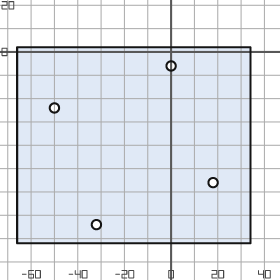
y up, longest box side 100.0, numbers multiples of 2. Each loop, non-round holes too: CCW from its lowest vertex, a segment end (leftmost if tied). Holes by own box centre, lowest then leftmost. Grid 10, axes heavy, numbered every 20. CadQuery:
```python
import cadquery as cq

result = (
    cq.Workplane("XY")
    .moveTo(-66.0, -82.0)
    .lineTo(34.0, -82.0)
    .lineTo(34.0, 2.0)
    .lineTo(-66.0, 2.0)
    .close()
    .moveTo(-32.0, -74.0)
    .circle(2.0)
    .moveTo(18.0, -56.0)
    .circle(2.0)
    .moveTo(-50.0, -24.0)
    .circle(2.0)
    .moveTo(0.0, -6.0)
    .circle(2.0)
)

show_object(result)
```